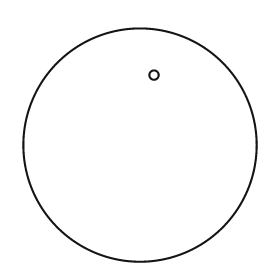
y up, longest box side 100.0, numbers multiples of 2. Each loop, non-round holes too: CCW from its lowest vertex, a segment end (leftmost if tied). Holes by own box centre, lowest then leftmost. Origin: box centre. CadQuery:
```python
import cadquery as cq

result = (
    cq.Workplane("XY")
    .moveTo(0.0, 0.0)
    .circle(50.0)
    .moveTo(6.0, 30.0)
    .circle(2.0)
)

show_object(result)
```